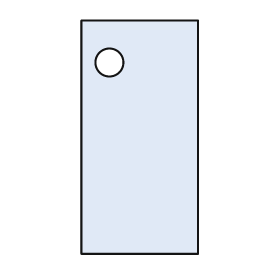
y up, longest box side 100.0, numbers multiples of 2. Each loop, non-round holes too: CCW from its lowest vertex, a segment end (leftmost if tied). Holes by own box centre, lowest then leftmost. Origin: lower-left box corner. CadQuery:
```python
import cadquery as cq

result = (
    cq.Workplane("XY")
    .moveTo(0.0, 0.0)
    .lineTo(50.0, 0.0)
    .lineTo(50.0, 100.0)
    .lineTo(0.0, 100.0)
    .close()
    .moveTo(12.0, 82.0)
    .circle(6.0)
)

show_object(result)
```